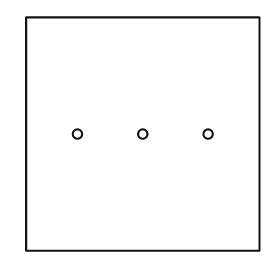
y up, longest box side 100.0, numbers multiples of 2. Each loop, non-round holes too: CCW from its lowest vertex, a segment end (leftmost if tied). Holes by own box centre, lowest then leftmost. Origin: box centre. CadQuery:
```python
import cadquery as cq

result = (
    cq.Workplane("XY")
    .moveTo(-50.0, -50.0)
    .lineTo(50.0, -50.0)
    .lineTo(50.0, 50.0)
    .lineTo(-50.0, 50.0)
    .close()
    .moveTo(-28.0, 0.0)
    .circle(2.0)
    .moveTo(0.0, 0.0)
    .circle(2.0)
    .moveTo(28.0, 0.0)
    .circle(2.0)
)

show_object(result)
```